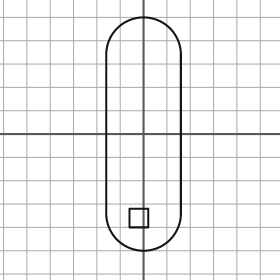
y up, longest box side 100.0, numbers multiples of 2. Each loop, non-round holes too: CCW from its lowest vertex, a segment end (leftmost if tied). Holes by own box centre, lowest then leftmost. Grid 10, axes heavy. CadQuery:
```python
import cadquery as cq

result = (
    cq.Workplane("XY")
    .moveTo(-16.0, -34.0)
    .threePointArc((0.0, -50.0), (16.0, -34.0))
    .lineTo(16.0, 34.0)
    .threePointArc((0.0, 50.0), (-16.0, 34.0))
    .close()
    .moveTo(-6.0, -40.0)
    .lineTo(2.0, -40.0)
    .lineTo(2.0, -32.0)
    .lineTo(-6.0, -32.0)
    .close()
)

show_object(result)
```